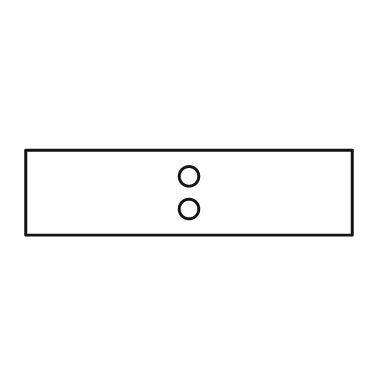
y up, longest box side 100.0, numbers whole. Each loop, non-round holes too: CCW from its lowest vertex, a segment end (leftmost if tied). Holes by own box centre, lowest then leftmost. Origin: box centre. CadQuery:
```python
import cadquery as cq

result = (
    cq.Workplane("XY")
    .moveTo(-50.0, -13.0)
    .lineTo(50.0, -13.0)
    .lineTo(50.0, 13.0)
    .lineTo(-50.0, 13.0)
    .close()
    .moveTo(0.0, -5.0)
    .circle(3.0)
    .moveTo(0.0, 5.0)
    .circle(3.0)
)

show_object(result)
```